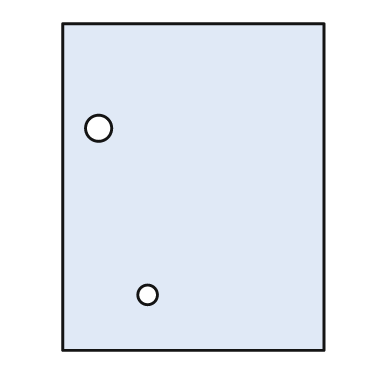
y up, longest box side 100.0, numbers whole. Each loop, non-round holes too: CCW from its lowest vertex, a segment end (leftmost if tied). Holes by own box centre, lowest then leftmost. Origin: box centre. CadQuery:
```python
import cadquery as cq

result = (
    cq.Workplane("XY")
    .moveTo(-40.0, -50.0)
    .lineTo(40.0, -50.0)
    .lineTo(40.0, 50.0)
    .lineTo(-40.0, 50.0)
    .close()
    .moveTo(-14.0, -33.0)
    .circle(3.0)
    .moveTo(-29.0, 18.0)
    .circle(4.0)
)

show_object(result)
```